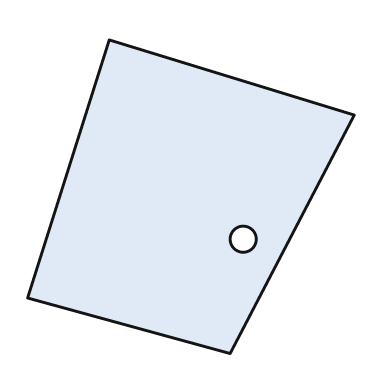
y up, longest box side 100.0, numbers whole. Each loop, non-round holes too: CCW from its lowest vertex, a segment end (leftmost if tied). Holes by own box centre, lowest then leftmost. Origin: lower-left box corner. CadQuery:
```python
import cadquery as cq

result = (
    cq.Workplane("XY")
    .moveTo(62.0, 0.0)
    .lineTo(100.0, 73.0)
    .lineTo(25.0, 96.0)
    .lineTo(0.0, 17.0)
    .close()
    .moveTo(66.0, 35.0)
    .circle(4.0)
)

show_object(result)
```